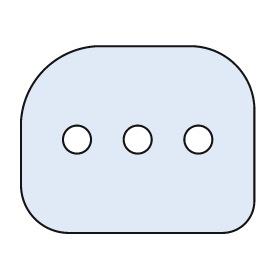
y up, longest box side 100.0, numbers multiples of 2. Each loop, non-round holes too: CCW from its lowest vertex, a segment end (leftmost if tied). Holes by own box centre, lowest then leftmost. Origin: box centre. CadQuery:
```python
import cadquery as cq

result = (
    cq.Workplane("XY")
    .moveTo(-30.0, -40.0)
    .lineTo(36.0, -40.0)
    .threePointArc((46.0, -36.0), (50.0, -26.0))
    .lineTo(50.0, 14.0)
    .threePointArc((42.0, 32.0), (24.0, 40.0))
    .lineTo(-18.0, 40.0)
    .threePointArc((-40.0, 30.0), (-50.0, 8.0))
    .lineTo(-50.0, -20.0)
    .threePointArc((-44.0, -34.0), (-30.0, -40.0))
    .close()
    .moveTo(-26.0, 0.0)
    .circle(6.0)
    .moveTo(0.0, 0.0)
    .circle(6.0)
    .moveTo(26.0, 0.0)
    .circle(6.0)
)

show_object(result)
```